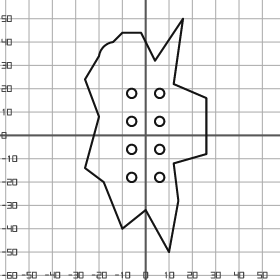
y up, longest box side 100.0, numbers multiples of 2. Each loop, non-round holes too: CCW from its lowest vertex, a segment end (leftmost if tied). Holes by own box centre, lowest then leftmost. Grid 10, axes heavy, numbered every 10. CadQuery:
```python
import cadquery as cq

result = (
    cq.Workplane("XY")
    .moveTo(10.0, -50.0)
    .lineTo(14.0, -28.0)
    .lineTo(12.0, -12.0)
    .lineTo(26.0, -8.0)
    .lineTo(26.0, 16.0)
    .lineTo(12.0, 22.0)
    .lineTo(16.0, 50.0)
    .lineTo(4.0, 32.0)
    .lineTo(-2.0, 44.0)
    .lineTo(-10.0, 44.0)
    .lineTo(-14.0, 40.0)
    .threePointArc((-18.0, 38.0), (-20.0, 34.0))
    .lineTo(-26.0, 24.0)
    .lineTo(-20.0, 8.0)
    .lineTo(-26.0, -14.0)
    .lineTo(-18.0, -20.0)
    .lineTo(-10.0, -40.0)
    .lineTo(0.0, -32.0)
    .close()
    .moveTo(-6.0, -18.0)
    .circle(2.0)
    .moveTo(6.0, -18.0)
    .circle(2.0)
    .moveTo(-6.0, -6.0)
    .circle(2.0)
    .moveTo(6.0, -6.0)
    .circle(2.0)
    .moveTo(-6.0, 6.0)
    .circle(2.0)
    .moveTo(6.0, 6.0)
    .circle(2.0)
    .moveTo(-6.0, 18.0)
    .circle(2.0)
    .moveTo(6.0, 18.0)
    .circle(2.0)
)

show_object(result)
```